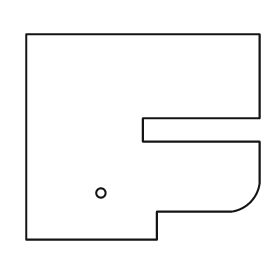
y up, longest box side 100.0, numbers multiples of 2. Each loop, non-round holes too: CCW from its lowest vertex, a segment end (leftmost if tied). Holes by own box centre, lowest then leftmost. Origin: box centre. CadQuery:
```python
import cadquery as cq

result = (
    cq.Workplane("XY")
    .moveTo(-50.0, -44.0)
    .lineTo(6.0, -44.0)
    .lineTo(6.0, -32.0)
    .lineTo(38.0, -32.0)
    .threePointArc((46.0, -28.0), (50.0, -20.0))
    .lineTo(50.0, -2.0)
    .lineTo(0.0, -2.0)
    .lineTo(0.0, 8.0)
    .lineTo(50.0, 8.0)
    .lineTo(50.0, 44.0)
    .lineTo(-50.0, 44.0)
    .close()
    .moveTo(-18.0, -24.0)
    .circle(2.0)
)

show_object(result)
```